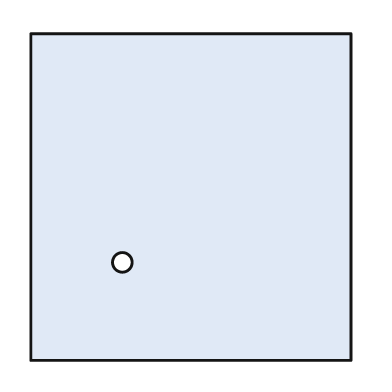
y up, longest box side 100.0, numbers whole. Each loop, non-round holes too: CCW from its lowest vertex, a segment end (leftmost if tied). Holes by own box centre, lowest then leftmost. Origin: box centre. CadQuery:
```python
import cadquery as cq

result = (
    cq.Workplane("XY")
    .moveTo(-49.0, -50.0)
    .lineTo(49.0, -50.0)
    .lineTo(49.0, 50.0)
    .lineTo(-49.0, 50.0)
    .close()
    .moveTo(-21.0, -20.0)
    .circle(3.0)
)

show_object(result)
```